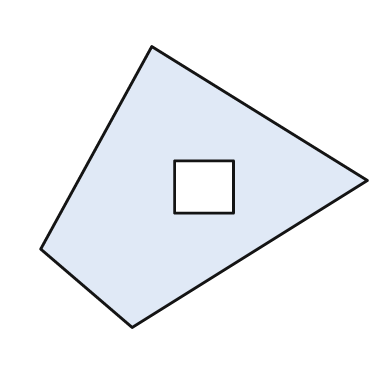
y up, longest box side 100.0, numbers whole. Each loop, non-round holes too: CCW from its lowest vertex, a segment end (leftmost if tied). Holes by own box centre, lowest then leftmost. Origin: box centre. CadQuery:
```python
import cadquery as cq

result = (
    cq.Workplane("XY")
    .moveTo(-22.0, -43.0)
    .lineTo(50.0, 2.0)
    .lineTo(-16.0, 43.0)
    .lineTo(-50.0, -19.0)
    .close()
    .moveTo(-9.0, -8.0)
    .lineTo(9.0, -8.0)
    .lineTo(9.0, 8.0)
    .lineTo(-9.0, 8.0)
    .close()
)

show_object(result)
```